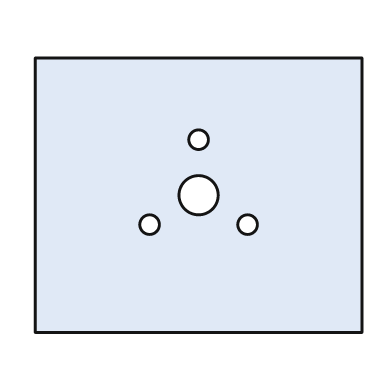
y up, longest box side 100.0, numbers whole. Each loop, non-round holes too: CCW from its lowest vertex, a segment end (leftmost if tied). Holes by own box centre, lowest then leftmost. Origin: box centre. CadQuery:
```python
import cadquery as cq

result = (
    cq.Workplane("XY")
    .moveTo(-50.0, -42.0)
    .lineTo(50.0, -42.0)
    .lineTo(50.0, 42.0)
    .lineTo(-50.0, 42.0)
    .close()
    .moveTo(-15.0, -9.0)
    .circle(3.0)
    .moveTo(15.0, -9.0)
    .circle(3.0)
    .moveTo(0.0, 0.0)
    .circle(6.0)
    .moveTo(0.0, 17.0)
    .circle(3.0)
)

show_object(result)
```